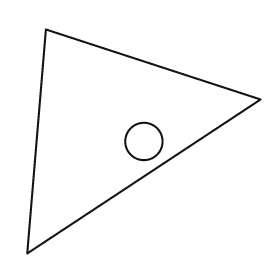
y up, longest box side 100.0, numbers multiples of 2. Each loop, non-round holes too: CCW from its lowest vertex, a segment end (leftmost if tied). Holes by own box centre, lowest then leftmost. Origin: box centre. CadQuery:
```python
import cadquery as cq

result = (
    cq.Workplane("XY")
    .moveTo(-50.0, -48.0)
    .lineTo(50.0, 18.0)
    .lineTo(-42.0, 48.0)
    .close()
    .moveTo(0.0, 0.0)
    .circle(8.0)
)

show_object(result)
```